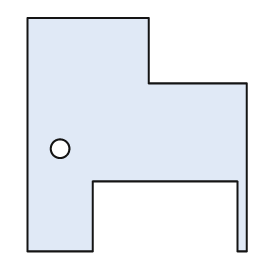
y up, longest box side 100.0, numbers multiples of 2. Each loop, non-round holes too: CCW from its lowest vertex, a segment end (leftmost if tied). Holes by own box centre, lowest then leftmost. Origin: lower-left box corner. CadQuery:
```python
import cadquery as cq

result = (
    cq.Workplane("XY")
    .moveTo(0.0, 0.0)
    .lineTo(28.0, 0.0)
    .lineTo(28.0, 30.0)
    .lineTo(90.0, 30.0)
    .lineTo(90.0, 0.0)
    .lineTo(94.0, 0.0)
    .lineTo(94.0, 72.0)
    .lineTo(52.0, 72.0)
    .lineTo(52.0, 100.0)
    .lineTo(0.0, 100.0)
    .close()
    .moveTo(14.0, 44.0)
    .circle(4.0)
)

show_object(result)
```